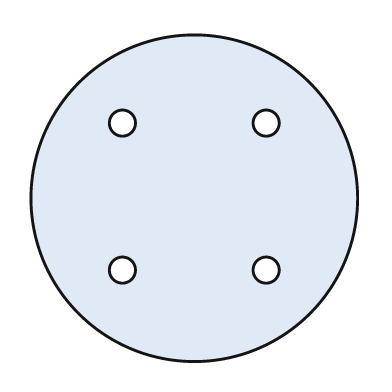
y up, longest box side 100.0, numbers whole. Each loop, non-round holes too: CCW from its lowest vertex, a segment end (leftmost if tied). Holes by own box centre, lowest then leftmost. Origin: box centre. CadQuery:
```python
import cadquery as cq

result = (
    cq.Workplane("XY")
    .moveTo(0.0, 0.0)
    .circle(50.0)
    .moveTo(-22.0, -22.0)
    .circle(4.0)
    .moveTo(22.0, -22.0)
    .circle(4.0)
    .moveTo(-22.0, 23.0)
    .circle(4.0)
    .moveTo(22.0, 23.0)
    .circle(4.0)
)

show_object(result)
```